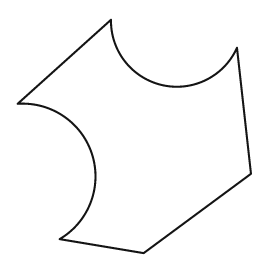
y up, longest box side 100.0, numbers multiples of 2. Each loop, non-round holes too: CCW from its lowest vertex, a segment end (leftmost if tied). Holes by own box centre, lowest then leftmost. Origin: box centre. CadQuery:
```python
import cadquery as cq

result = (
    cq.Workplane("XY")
    .moveTo(4.0, -50.0)
    .lineTo(50.0, -16.0)
    .lineTo(44.0, 38.0)
    .threePointArc((12.0, 22.0), (-10.0, 50.0))
    .lineTo(-50.0, 14.0)
    .threePointArc((-18.0, -8.0), (-32.0, -44.0))
    .close()
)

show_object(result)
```